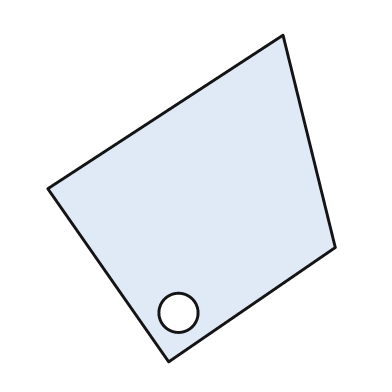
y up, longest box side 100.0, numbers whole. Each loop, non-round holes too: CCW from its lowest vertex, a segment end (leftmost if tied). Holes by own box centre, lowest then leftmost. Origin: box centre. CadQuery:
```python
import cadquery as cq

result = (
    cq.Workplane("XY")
    .moveTo(-7.0, -50.0)
    .lineTo(44.0, -15.0)
    .lineTo(28.0, 50.0)
    .lineTo(-44.0, 3.0)
    .close()
    .moveTo(-4.0, -35.0)
    .circle(6.0)
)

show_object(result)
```